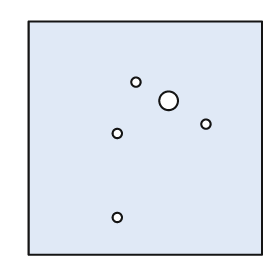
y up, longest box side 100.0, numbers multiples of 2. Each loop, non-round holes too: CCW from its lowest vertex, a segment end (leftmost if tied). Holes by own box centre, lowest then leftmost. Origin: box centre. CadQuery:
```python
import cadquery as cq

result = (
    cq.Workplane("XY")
    .moveTo(-50.0, -50.0)
    .lineTo(50.0, -50.0)
    .lineTo(50.0, 50.0)
    .lineTo(-50.0, 50.0)
    .close()
    .moveTo(-12.0, -34.0)
    .circle(2.0)
    .moveTo(-12.0, 2.0)
    .circle(2.0)
    .moveTo(26.0, 6.0)
    .circle(2.0)
    .moveTo(10.0, 16.0)
    .circle(4.0)
    .moveTo(-4.0, 24.0)
    .circle(2.0)
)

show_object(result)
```